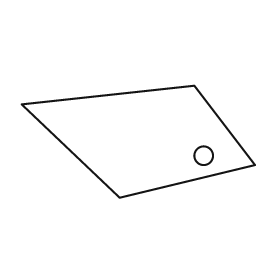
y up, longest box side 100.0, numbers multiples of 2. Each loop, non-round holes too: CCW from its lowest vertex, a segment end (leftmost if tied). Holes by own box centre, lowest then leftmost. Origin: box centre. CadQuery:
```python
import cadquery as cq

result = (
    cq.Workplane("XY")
    .moveTo(-8.0, -24.0)
    .lineTo(50.0, -10.0)
    .lineTo(24.0, 24.0)
    .lineTo(-50.0, 16.0)
    .close()
    .moveTo(28.0, -6.0)
    .circle(4.0)
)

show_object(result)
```